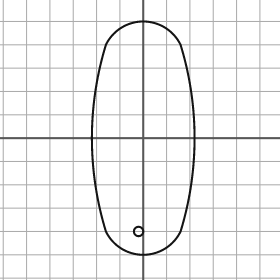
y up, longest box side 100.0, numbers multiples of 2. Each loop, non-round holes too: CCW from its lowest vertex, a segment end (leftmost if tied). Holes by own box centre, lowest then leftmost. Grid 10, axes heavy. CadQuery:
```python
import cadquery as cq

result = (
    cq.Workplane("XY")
    .moveTo(-16.0, -40.0)
    .threePointArc((0.0, -50.0), (16.0, -40.0))
    .threePointArc((22.0, 0.0), (16.0, 40.0))
    .threePointArc((0.0, 50.0), (-16.0, 40.0))
    .threePointArc((-22.0, 0.0), (-16.0, -40.0))
    .close()
    .moveTo(-2.0, -40.0)
    .circle(2.0)
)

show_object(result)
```